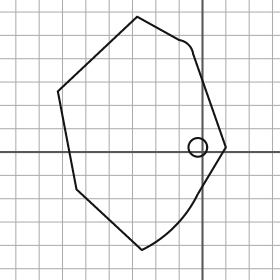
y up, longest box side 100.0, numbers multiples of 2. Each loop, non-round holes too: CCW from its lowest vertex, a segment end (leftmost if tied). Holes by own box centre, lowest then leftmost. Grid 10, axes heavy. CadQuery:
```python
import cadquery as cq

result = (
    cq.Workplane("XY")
    .moveTo(-26.0, -42.0)
    .threePointArc((-12.0, -32.0), (-2.0, -18.0))
    .lineTo(10.0, 2.0)
    .lineTo(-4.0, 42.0)
    .threePointArc((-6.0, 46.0), (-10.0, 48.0))
    .lineTo(-28.0, 58.0)
    .lineTo(-62.0, 26.0)
    .lineTo(-54.0, -16.0)
    .close()
    .moveTo(-2.0, 2.0)
    .circle(4.0)
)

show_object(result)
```